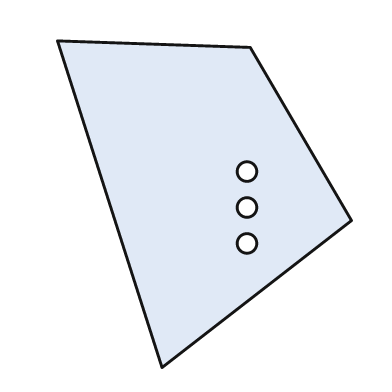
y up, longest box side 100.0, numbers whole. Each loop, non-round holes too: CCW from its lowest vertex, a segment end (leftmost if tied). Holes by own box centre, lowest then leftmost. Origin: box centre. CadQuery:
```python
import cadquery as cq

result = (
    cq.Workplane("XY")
    .moveTo(-13.0, -50.0)
    .lineTo(45.0, -5.0)
    .lineTo(14.0, 48.0)
    .lineTo(-45.0, 50.0)
    .close()
    .moveTo(13.0, -12.0)
    .circle(3.0)
    .moveTo(13.0, -1.0)
    .circle(3.0)
    .moveTo(13.0, 10.0)
    .circle(3.0)
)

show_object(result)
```